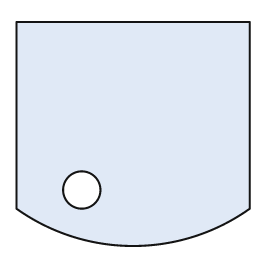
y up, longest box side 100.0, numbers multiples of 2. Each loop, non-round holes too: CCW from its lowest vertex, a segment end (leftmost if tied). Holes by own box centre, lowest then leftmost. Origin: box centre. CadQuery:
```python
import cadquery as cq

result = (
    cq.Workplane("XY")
    .moveTo(-50.0, -32.0)
    .threePointArc((0.0, -48.0), (50.0, -32.0))
    .lineTo(50.0, 48.0)
    .lineTo(-50.0, 48.0)
    .close()
    .moveTo(-22.0, -24.0)
    .circle(8.0)
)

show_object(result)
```